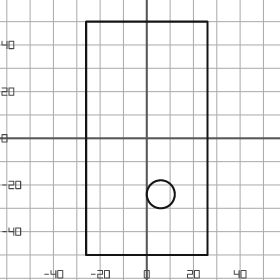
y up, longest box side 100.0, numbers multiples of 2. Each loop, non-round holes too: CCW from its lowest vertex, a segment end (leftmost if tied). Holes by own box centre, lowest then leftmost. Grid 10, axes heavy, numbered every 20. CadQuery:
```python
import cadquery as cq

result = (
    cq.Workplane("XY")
    .moveTo(-26.0, -50.0)
    .lineTo(26.0, -50.0)
    .lineTo(26.0, 50.0)
    .lineTo(-26.0, 50.0)
    .close()
    .moveTo(6.0, -24.0)
    .circle(6.0)
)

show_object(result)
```